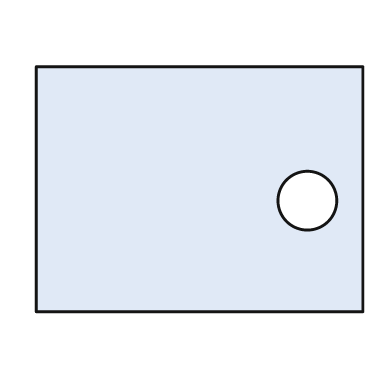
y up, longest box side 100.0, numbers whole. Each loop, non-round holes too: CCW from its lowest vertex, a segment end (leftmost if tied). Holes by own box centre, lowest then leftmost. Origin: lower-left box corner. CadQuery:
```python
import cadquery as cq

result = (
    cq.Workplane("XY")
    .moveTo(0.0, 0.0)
    .lineTo(100.0, 0.0)
    .lineTo(100.0, 75.0)
    .lineTo(0.0, 75.0)
    .close()
    .moveTo(83.0, 34.0)
    .circle(9.0)
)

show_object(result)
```